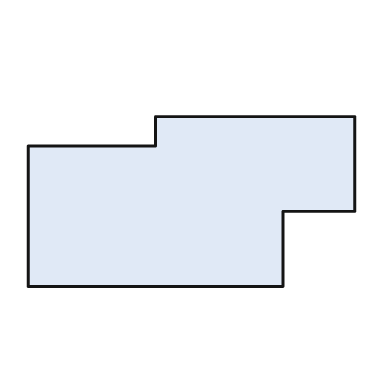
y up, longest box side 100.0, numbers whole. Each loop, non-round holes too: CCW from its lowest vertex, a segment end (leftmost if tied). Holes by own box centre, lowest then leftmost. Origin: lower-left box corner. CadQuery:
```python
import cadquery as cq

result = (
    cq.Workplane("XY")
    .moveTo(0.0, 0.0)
    .lineTo(78.0, 0.0)
    .lineTo(78.0, 23.0)
    .lineTo(100.0, 23.0)
    .lineTo(100.0, 52.0)
    .lineTo(39.0, 52.0)
    .lineTo(39.0, 43.0)
    .lineTo(0.0, 43.0)
    .close()
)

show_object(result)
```